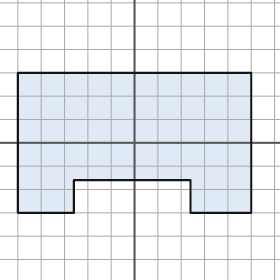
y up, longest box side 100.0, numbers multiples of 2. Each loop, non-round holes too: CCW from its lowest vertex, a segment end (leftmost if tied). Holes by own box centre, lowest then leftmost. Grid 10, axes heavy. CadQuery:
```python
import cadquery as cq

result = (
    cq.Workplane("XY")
    .moveTo(-50.0, -30.0)
    .lineTo(-26.0, -30.0)
    .lineTo(-26.0, -16.0)
    .lineTo(24.0, -16.0)
    .lineTo(24.0, -30.0)
    .lineTo(50.0, -30.0)
    .lineTo(50.0, 30.0)
    .lineTo(-50.0, 30.0)
    .close()
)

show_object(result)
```